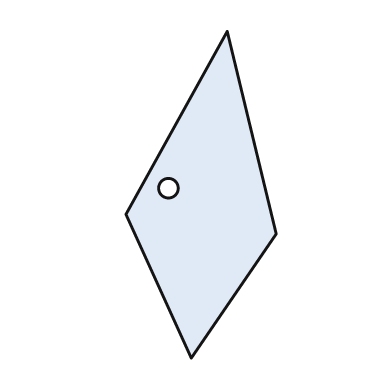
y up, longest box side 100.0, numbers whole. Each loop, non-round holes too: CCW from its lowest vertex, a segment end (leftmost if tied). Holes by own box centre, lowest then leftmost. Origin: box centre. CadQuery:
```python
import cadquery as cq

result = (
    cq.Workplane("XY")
    .moveTo(-3.0, -50.0)
    .lineTo(23.0, -12.0)
    .lineTo(8.0, 50.0)
    .lineTo(-23.0, -6.0)
    .close()
    .moveTo(-10.0, 2.0)
    .circle(3.0)
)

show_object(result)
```